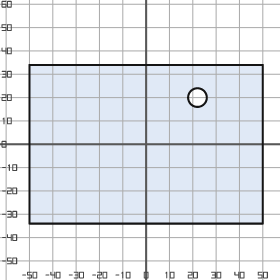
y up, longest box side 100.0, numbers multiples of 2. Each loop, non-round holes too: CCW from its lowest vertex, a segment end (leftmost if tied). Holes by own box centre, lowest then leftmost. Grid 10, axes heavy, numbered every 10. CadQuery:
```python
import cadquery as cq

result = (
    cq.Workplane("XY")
    .moveTo(-50.0, -34.0)
    .lineTo(50.0, -34.0)
    .lineTo(50.0, 34.0)
    .lineTo(-50.0, 34.0)
    .close()
    .moveTo(22.0, 20.0)
    .circle(4.0)
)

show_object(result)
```